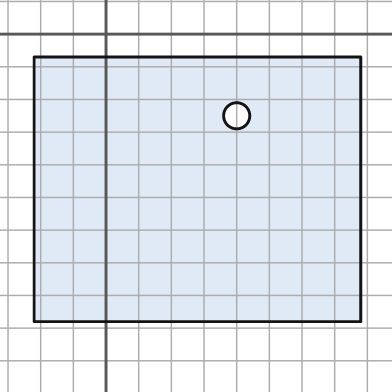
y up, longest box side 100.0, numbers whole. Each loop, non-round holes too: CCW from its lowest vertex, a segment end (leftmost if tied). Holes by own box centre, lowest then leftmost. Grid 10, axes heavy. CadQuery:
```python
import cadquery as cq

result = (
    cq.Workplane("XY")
    .moveTo(-22.0, -88.0)
    .lineTo(78.0, -88.0)
    .lineTo(78.0, -7.0)
    .lineTo(-22.0, -7.0)
    .close()
    .moveTo(40.0, -25.0)
    .circle(4.0)
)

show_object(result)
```